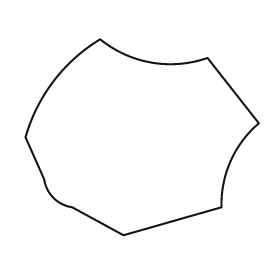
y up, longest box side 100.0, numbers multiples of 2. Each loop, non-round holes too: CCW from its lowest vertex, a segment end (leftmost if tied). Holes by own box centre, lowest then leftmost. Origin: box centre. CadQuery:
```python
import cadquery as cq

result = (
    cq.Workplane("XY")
    .moveTo(-8.0, -42.0)
    .lineTo(34.0, -30.0)
    .threePointArc((38.0, -10.0), (50.0, 6.0))
    .lineTo(28.0, 34.0)
    .threePointArc((4.0, 32.0), (-18.0, 42.0))
    .threePointArc((-38.0, 24.0), (-50.0, 0.0))
    .lineTo(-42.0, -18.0)
    .threePointArc((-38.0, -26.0), (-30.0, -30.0))
    .close()
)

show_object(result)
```